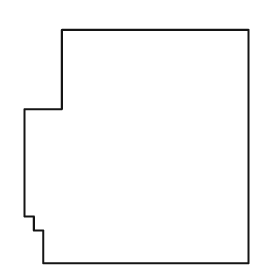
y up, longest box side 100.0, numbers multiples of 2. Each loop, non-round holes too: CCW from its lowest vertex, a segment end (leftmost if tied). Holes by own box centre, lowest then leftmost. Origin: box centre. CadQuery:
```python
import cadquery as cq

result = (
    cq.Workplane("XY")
    .moveTo(-40.0, -50.0)
    .lineTo(48.0, -50.0)
    .lineTo(48.0, 50.0)
    .lineTo(-32.0, 50.0)
    .lineTo(-32.0, 16.0)
    .lineTo(-48.0, 16.0)
    .lineTo(-48.0, -30.0)
    .lineTo(-44.0, -30.0)
    .lineTo(-44.0, -36.0)
    .lineTo(-40.0, -36.0)
    .close()
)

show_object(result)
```